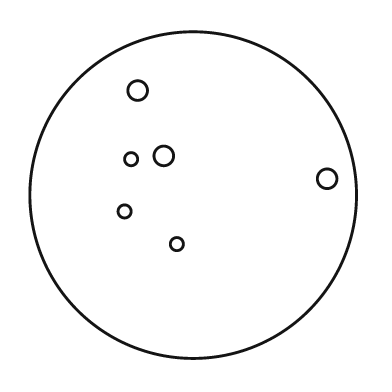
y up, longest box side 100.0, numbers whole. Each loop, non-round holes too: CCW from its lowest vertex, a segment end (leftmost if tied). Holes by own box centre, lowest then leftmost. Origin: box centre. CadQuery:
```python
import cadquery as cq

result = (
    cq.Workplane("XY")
    .moveTo(0.0, 0.0)
    .circle(50.0)
    .moveTo(-5.0, -15.0)
    .circle(2.0)
    .moveTo(-21.0, -5.0)
    .circle(2.0)
    .moveTo(41.0, 5.0)
    .circle(3.0)
    .moveTo(-19.0, 11.0)
    .circle(2.0)
    .moveTo(-9.0, 12.0)
    .circle(3.0)
    .moveTo(-17.0, 32.0)
    .circle(3.0)
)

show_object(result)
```